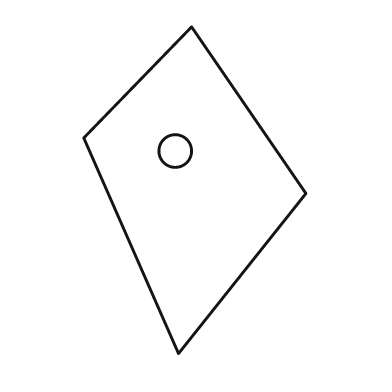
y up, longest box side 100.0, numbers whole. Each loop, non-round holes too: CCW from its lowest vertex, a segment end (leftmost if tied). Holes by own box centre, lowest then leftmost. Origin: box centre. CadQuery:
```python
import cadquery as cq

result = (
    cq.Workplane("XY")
    .moveTo(-5.0, -50.0)
    .lineTo(34.0, -1.0)
    .lineTo(-1.0, 50.0)
    .lineTo(-34.0, 16.0)
    .close()
    .moveTo(-6.0, 12.0)
    .circle(5.0)
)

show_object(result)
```